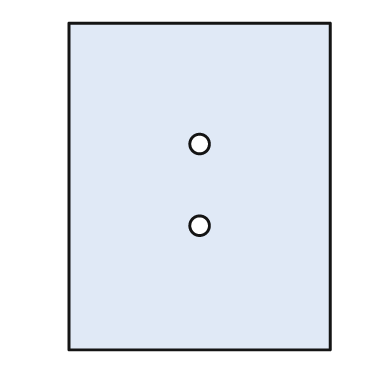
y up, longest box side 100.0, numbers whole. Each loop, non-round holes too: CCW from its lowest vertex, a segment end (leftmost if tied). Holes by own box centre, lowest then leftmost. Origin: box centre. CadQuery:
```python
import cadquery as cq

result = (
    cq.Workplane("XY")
    .moveTo(-40.0, -50.0)
    .lineTo(40.0, -50.0)
    .lineTo(40.0, 50.0)
    .lineTo(-40.0, 50.0)
    .close()
    .moveTo(0.0, -12.0)
    .circle(3.0)
    .moveTo(0.0, 13.0)
    .circle(3.0)
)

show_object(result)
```